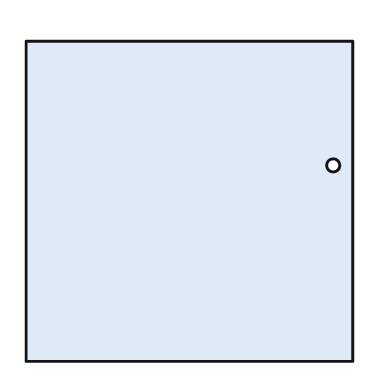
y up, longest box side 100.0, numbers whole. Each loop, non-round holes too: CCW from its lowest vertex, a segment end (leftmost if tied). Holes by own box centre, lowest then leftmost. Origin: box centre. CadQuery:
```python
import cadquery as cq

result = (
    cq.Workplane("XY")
    .moveTo(-50.0, -49.0)
    .lineTo(50.0, -49.0)
    .lineTo(50.0, 49.0)
    .lineTo(-50.0, 49.0)
    .close()
    .moveTo(44.0, 11.0)
    .circle(2.0)
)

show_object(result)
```